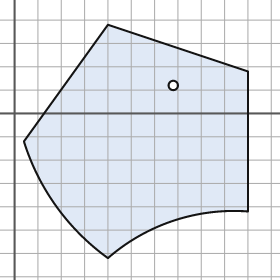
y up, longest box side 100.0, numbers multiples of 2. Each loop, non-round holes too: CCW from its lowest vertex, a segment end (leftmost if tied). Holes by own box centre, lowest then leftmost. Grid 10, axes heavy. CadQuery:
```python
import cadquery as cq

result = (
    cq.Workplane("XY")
    .moveTo(40.0, -62.0)
    .threePointArc((68.0, -46.0), (100.0, -42.0))
    .lineTo(100.0, 18.0)
    .lineTo(40.0, 38.0)
    .lineTo(4.0, -12.0)
    .threePointArc((18.0, -40.0), (40.0, -62.0))
    .close()
    .moveTo(68.0, 12.0)
    .circle(2.0)
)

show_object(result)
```